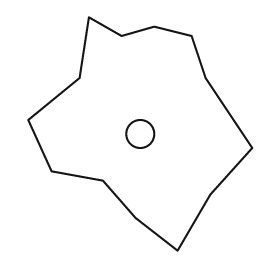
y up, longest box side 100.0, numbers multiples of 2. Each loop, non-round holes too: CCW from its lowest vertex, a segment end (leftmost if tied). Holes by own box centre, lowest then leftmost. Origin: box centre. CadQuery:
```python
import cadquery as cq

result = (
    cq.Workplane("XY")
    .moveTo(16.0, -50.0)
    .lineTo(30.0, -26.0)
    .lineTo(48.0, -6.0)
    .lineTo(28.0, 24.0)
    .lineTo(22.0, 42.0)
    .lineTo(6.0, 46.0)
    .lineTo(-8.0, 42.0)
    .lineTo(-22.0, 50.0)
    .lineTo(-26.0, 24.0)
    .lineTo(-48.0, 6.0)
    .lineTo(-38.0, -16.0)
    .lineTo(-16.0, -20.0)
    .lineTo(-2.0, -36.0)
    .close()
    .moveTo(0.0, 0.0)
    .circle(6.0)
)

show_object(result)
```